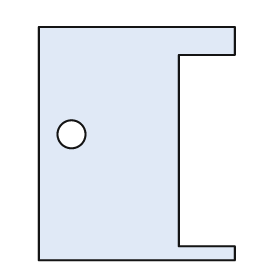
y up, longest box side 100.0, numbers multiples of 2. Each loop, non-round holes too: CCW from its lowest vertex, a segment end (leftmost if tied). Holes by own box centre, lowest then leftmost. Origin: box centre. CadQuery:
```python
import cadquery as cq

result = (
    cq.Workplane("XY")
    .moveTo(-42.0, -50.0)
    .lineTo(42.0, -50.0)
    .lineTo(42.0, -44.0)
    .lineTo(18.0, -44.0)
    .lineTo(18.0, 38.0)
    .lineTo(42.0, 38.0)
    .lineTo(42.0, 50.0)
    .lineTo(-42.0, 50.0)
    .close()
    .moveTo(-28.0, 4.0)
    .circle(6.0)
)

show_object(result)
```